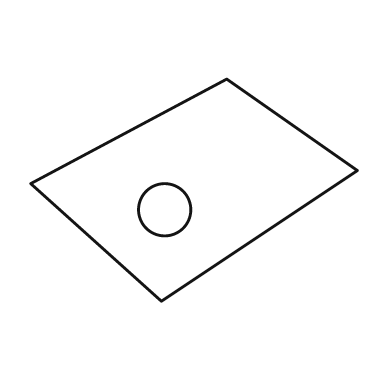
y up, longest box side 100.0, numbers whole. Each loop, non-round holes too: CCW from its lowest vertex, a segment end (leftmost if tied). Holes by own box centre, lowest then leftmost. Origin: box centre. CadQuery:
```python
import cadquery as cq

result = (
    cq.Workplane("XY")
    .moveTo(-10.0, -34.0)
    .lineTo(50.0, 6.0)
    .lineTo(10.0, 34.0)
    .lineTo(-50.0, 2.0)
    .close()
    .moveTo(-9.0, -6.0)
    .circle(8.0)
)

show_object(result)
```